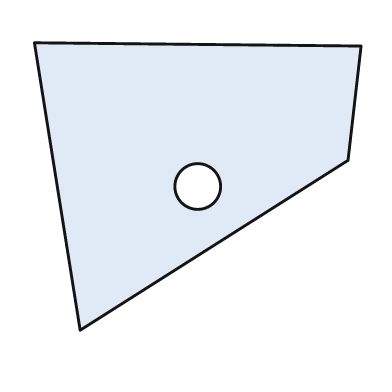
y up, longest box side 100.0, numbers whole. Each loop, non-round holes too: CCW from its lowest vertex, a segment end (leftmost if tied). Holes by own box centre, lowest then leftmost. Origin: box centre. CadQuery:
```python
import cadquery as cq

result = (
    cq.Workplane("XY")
    .moveTo(-36.0, -44.0)
    .lineTo(46.0, 8.0)
    .lineTo(50.0, 43.0)
    .lineTo(-50.0, 44.0)
    .close()
    .moveTo(0.0, 0.0)
    .circle(7.0)
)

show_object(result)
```